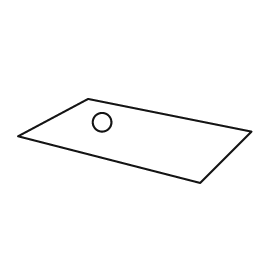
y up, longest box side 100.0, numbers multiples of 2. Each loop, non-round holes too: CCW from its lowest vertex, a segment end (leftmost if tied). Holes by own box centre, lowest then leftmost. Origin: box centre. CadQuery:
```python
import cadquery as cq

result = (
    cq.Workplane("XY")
    .moveTo(28.0, -18.0)
    .lineTo(50.0, 4.0)
    .lineTo(-20.0, 18.0)
    .lineTo(-50.0, 2.0)
    .close()
    .moveTo(-14.0, 8.0)
    .circle(4.0)
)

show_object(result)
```